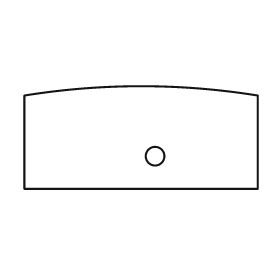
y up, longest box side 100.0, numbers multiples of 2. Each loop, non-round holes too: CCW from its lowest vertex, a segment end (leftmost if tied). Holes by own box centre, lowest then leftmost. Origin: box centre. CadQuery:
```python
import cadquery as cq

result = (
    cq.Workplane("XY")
    .moveTo(-50.0, -22.0)
    .lineTo(50.0, -22.0)
    .lineTo(50.0, 18.0)
    .threePointArc((0.0, 22.0), (-50.0, 18.0))
    .close()
    .moveTo(6.0, -8.0)
    .circle(4.0)
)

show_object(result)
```